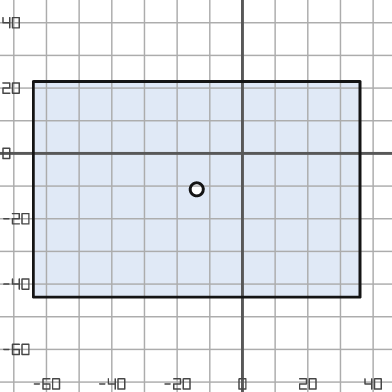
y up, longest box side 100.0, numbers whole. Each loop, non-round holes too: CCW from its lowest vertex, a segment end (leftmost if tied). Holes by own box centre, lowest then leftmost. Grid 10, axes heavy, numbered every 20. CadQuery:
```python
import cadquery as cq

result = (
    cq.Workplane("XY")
    .moveTo(-64.0, -44.0)
    .lineTo(36.0, -44.0)
    .lineTo(36.0, 22.0)
    .lineTo(-64.0, 22.0)
    .close()
    .moveTo(-14.0, -11.0)
    .circle(2.0)
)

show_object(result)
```